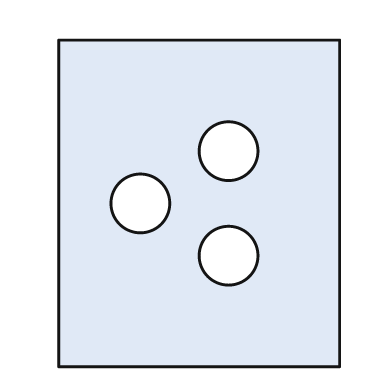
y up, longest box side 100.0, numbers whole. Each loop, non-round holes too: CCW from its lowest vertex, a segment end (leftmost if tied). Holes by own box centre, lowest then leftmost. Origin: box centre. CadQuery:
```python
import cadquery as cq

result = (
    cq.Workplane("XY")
    .moveTo(-43.0, -50.0)
    .lineTo(43.0, -50.0)
    .lineTo(43.0, 50.0)
    .lineTo(-43.0, 50.0)
    .close()
    .moveTo(9.0, -16.0)
    .circle(9.0)
    .moveTo(-18.0, 0.0)
    .circle(9.0)
    .moveTo(9.0, 16.0)
    .circle(9.0)
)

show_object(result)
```